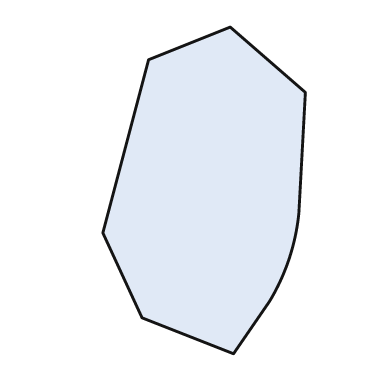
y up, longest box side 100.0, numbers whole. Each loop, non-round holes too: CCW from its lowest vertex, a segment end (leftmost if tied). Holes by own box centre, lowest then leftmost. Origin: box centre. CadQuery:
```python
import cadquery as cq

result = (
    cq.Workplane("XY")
    .moveTo(9.0, -50.0)
    .lineTo(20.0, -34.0)
    .threePointArc((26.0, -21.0), (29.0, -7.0))
    .lineTo(31.0, 30.0)
    .lineTo(8.0, 50.0)
    .lineTo(-17.0, 40.0)
    .lineTo(-31.0, -13.0)
    .lineTo(-19.0, -39.0)
    .close()
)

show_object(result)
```